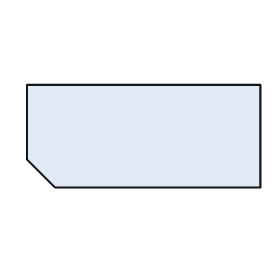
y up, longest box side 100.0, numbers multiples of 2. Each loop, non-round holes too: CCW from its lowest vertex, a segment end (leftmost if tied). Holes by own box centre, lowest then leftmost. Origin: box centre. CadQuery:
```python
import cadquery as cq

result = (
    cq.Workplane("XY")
    .moveTo(-38.0, -22.0)
    .lineTo(50.0, -22.0)
    .lineTo(50.0, 22.0)
    .lineTo(-50.0, 22.0)
    .lineTo(-50.0, -10.0)
    .close()
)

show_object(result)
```